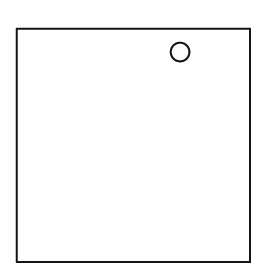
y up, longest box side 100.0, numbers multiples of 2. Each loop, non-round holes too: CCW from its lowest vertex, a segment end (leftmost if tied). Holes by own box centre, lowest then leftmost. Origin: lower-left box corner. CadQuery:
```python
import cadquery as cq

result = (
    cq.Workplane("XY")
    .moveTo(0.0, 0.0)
    .lineTo(100.0, 0.0)
    .lineTo(100.0, 100.0)
    .lineTo(0.0, 100.0)
    .close()
    .moveTo(70.0, 90.0)
    .circle(4.0)
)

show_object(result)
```